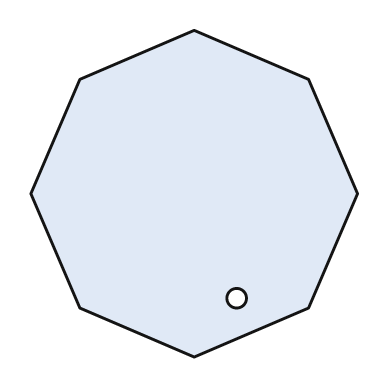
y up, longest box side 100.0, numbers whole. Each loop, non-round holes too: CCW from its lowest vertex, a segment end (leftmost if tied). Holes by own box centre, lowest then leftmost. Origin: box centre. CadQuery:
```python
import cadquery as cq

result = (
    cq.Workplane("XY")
    .moveTo(0.0, -50.0)
    .lineTo(35.0, -35.0)
    .lineTo(50.0, 0.0)
    .lineTo(35.0, 35.0)
    .lineTo(0.0, 50.0)
    .lineTo(-35.0, 35.0)
    .lineTo(-50.0, 0.0)
    .lineTo(-35.0, -35.0)
    .close()
    .moveTo(13.0, -32.0)
    .circle(3.0)
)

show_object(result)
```